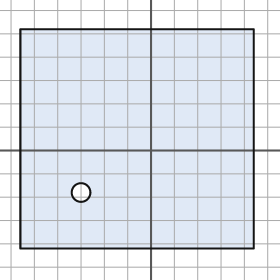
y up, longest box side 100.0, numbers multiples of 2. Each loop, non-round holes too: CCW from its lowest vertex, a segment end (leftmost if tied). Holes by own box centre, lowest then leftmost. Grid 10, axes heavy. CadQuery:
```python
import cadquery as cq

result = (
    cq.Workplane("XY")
    .moveTo(-56.0, -42.0)
    .lineTo(44.0, -42.0)
    .lineTo(44.0, 52.0)
    .lineTo(-56.0, 52.0)
    .close()
    .moveTo(-30.0, -18.0)
    .circle(4.0)
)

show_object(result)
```